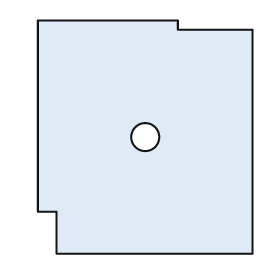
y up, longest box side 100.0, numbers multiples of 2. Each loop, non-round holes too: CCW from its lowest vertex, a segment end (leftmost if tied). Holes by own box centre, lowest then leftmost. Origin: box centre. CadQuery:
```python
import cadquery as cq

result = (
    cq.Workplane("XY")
    .moveTo(-38.0, -50.0)
    .lineTo(46.0, -50.0)
    .lineTo(46.0, 46.0)
    .lineTo(14.0, 46.0)
    .lineTo(14.0, 50.0)
    .lineTo(-46.0, 50.0)
    .lineTo(-46.0, -32.0)
    .lineTo(-38.0, -32.0)
    .close()
    .moveTo(0.0, 0.0)
    .circle(6.0)
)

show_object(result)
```